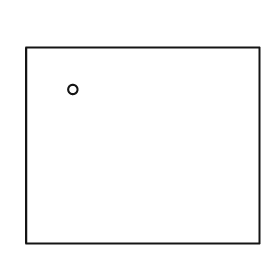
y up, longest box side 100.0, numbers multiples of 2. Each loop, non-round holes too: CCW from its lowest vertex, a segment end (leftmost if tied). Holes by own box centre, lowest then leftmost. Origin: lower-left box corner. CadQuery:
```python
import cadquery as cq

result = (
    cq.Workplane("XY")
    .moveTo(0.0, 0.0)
    .lineTo(100.0, 0.0)
    .lineTo(100.0, 84.0)
    .lineTo(0.0, 84.0)
    .close()
    .moveTo(20.0, 66.0)
    .circle(2.0)
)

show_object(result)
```